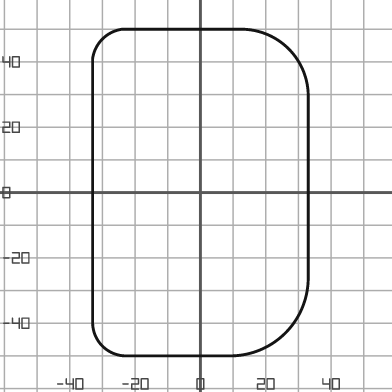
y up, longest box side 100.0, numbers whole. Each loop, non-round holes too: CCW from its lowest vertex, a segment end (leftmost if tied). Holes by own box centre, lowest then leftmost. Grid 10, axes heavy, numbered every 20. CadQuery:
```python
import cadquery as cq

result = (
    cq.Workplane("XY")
    .moveTo(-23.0, -50.0)
    .lineTo(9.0, -50.0)
    .threePointArc((26.0, -43.0), (33.0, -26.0))
    .lineTo(33.0, 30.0)
    .threePointArc((27.0, 44.0), (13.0, 50.0))
    .lineTo(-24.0, 50.0)
    .threePointArc((-30.0, 47.0), (-33.0, 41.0))
    .lineTo(-33.0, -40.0)
    .threePointArc((-30.0, -47.0), (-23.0, -50.0))
    .close()
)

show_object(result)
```